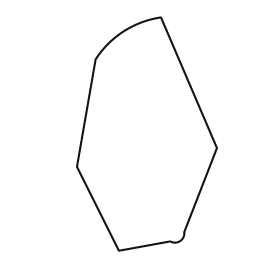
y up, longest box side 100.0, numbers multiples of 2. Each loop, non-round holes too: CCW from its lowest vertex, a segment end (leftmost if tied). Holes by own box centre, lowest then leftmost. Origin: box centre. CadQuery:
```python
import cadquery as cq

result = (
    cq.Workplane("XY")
    .moveTo(-12.0, -50.0)
    .lineTo(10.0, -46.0)
    .threePointArc((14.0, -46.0), (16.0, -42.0))
    .lineTo(30.0, -6.0)
    .lineTo(6.0, 50.0)
    .threePointArc((-10.0, 44.0), (-22.0, 32.0))
    .lineTo(-30.0, -14.0)
    .close()
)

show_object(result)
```